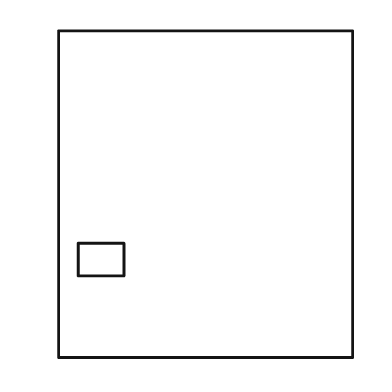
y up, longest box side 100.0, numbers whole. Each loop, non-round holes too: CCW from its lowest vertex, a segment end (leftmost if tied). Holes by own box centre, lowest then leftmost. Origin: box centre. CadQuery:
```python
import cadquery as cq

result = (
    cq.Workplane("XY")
    .moveTo(-45.0, -50.0)
    .lineTo(45.0, -50.0)
    .lineTo(45.0, 50.0)
    .lineTo(-45.0, 50.0)
    .close()
    .moveTo(-39.0, -25.0)
    .lineTo(-25.0, -25.0)
    .lineTo(-25.0, -15.0)
    .lineTo(-39.0, -15.0)
    .close()
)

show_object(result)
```